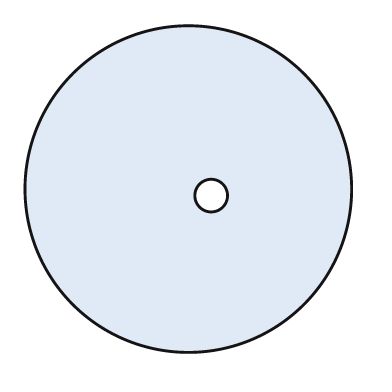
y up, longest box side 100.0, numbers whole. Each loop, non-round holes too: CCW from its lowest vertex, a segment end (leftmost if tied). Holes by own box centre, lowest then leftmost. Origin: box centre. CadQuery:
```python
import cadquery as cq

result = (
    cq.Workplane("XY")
    .moveTo(0.0, 0.0)
    .circle(50.0)
    .moveTo(7.0, -2.0)
    .circle(5.0)
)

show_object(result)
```